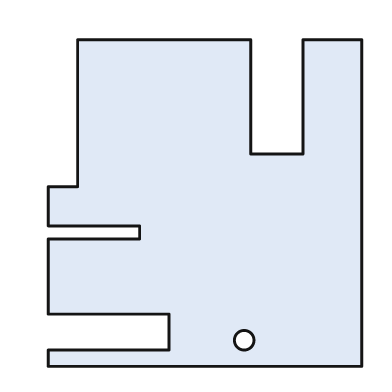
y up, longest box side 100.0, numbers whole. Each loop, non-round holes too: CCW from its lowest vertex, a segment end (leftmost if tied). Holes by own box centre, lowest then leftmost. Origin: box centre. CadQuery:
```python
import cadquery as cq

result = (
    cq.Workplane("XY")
    .moveTo(-48.0, -50.0)
    .lineTo(48.0, -50.0)
    .lineTo(48.0, 50.0)
    .lineTo(30.0, 50.0)
    .lineTo(30.0, 15.0)
    .lineTo(14.0, 15.0)
    .lineTo(14.0, 50.0)
    .lineTo(-39.0, 50.0)
    .lineTo(-39.0, 5.0)
    .lineTo(-48.0, 5.0)
    .lineTo(-48.0, -7.0)
    .lineTo(-20.0, -7.0)
    .lineTo(-20.0, -11.0)
    .lineTo(-48.0, -11.0)
    .lineTo(-48.0, -34.0)
    .lineTo(-11.0, -34.0)
    .lineTo(-11.0, -45.0)
    .lineTo(-48.0, -45.0)
    .close()
    .moveTo(12.0, -42.0)
    .circle(3.0)
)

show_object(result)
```